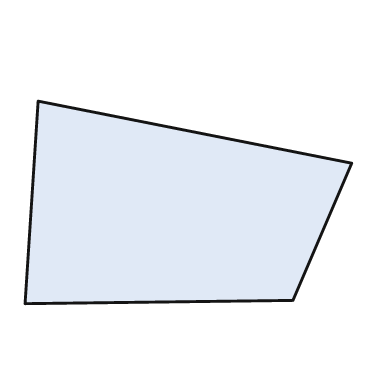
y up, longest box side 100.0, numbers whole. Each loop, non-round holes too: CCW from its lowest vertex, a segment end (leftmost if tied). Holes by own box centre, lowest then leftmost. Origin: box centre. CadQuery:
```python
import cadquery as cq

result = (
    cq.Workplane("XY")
    .moveTo(-50.0, -31.0)
    .lineTo(32.0, -30.0)
    .lineTo(50.0, 12.0)
    .lineTo(-46.0, 31.0)
    .close()
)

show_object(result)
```